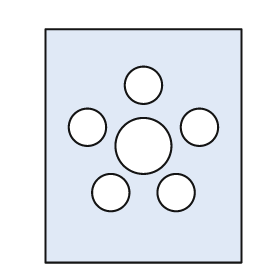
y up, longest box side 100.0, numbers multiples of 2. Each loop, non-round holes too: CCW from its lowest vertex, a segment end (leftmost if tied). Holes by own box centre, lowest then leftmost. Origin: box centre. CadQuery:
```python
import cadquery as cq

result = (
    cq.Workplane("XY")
    .moveTo(-42.0, -50.0)
    .lineTo(42.0, -50.0)
    .lineTo(42.0, 50.0)
    .lineTo(-42.0, 50.0)
    .close()
    .moveTo(-14.0, -20.0)
    .circle(8.0)
    .moveTo(14.0, -20.0)
    .circle(8.0)
    .moveTo(0.0, 0.0)
    .circle(12.0)
    .moveTo(-24.0, 8.0)
    .circle(8.0)
    .moveTo(24.0, 8.0)
    .circle(8.0)
    .moveTo(0.0, 26.0)
    .circle(8.0)
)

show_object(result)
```